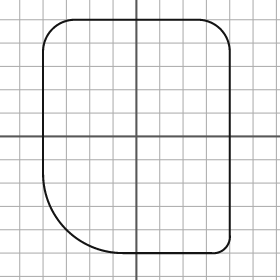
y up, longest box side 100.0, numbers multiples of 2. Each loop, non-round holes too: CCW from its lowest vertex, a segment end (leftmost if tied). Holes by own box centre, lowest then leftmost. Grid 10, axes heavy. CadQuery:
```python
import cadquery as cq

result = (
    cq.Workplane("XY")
    .moveTo(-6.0, -50.0)
    .lineTo(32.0, -50.0)
    .threePointArc((38.0, -48.0), (40.0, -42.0))
    .lineTo(40.0, 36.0)
    .threePointArc((36.0, 46.0), (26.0, 50.0))
    .lineTo(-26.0, 50.0)
    .threePointArc((-36.0, 46.0), (-40.0, 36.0))
    .lineTo(-40.0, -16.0)
    .threePointArc((-30.0, -40.0), (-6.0, -50.0))
    .close()
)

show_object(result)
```